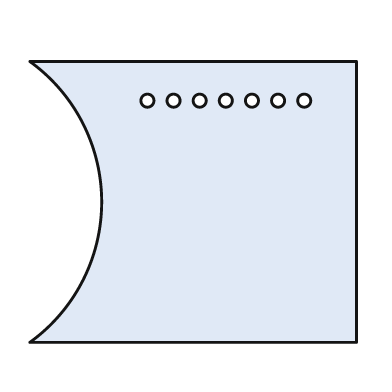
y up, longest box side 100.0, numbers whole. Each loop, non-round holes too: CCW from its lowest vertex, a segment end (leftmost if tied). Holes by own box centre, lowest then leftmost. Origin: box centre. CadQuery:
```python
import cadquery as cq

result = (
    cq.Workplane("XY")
    .moveTo(-50.0, -43.0)
    .lineTo(50.0, -43.0)
    .lineTo(50.0, 43.0)
    .lineTo(-50.0, 43.0)
    .threePointArc((-28.0, 0.0), (-50.0, -43.0))
    .close()
    .moveTo(-14.0, 31.0)
    .circle(2.0)
    .moveTo(-6.0, 31.0)
    .circle(2.0)
    .moveTo(2.0, 31.0)
    .circle(2.0)
    .moveTo(10.0, 31.0)
    .circle(2.0)
    .moveTo(18.0, 31.0)
    .circle(2.0)
    .moveTo(26.0, 31.0)
    .circle(2.0)
    .moveTo(34.0, 31.0)
    .circle(2.0)
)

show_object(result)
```